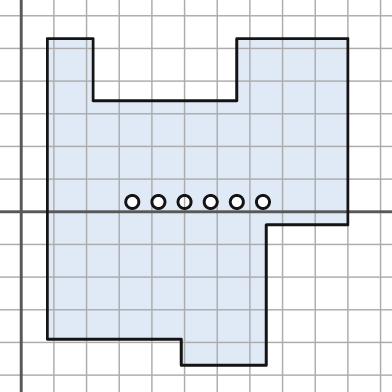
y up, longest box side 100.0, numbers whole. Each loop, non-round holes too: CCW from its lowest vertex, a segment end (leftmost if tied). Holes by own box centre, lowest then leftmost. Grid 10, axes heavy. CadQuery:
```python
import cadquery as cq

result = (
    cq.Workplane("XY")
    .moveTo(49.0, -47.0)
    .lineTo(75.0, -47.0)
    .lineTo(75.0, -4.0)
    .lineTo(100.0, -4.0)
    .lineTo(100.0, 53.0)
    .lineTo(66.0, 53.0)
    .lineTo(66.0, 34.0)
    .lineTo(22.0, 34.0)
    .lineTo(22.0, 53.0)
    .lineTo(8.0, 53.0)
    .lineTo(8.0, -39.0)
    .lineTo(49.0, -39.0)
    .close()
    .moveTo(34.0, 3.0)
    .circle(2.0)
    .moveTo(42.0, 3.0)
    .circle(2.0)
    .moveTo(50.0, 3.0)
    .circle(2.0)
    .moveTo(58.0, 3.0)
    .circle(2.0)
    .moveTo(66.0, 3.0)
    .circle(2.0)
    .moveTo(74.0, 3.0)
    .circle(2.0)
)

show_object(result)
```